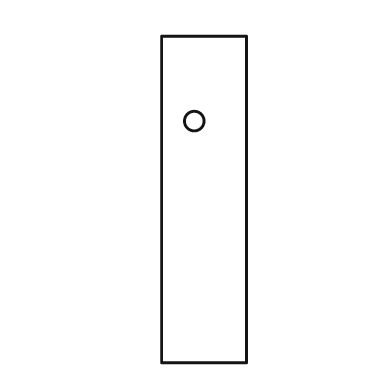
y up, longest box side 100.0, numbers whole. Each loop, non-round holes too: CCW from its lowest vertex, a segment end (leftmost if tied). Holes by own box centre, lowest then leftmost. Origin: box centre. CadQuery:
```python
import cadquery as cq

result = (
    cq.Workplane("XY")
    .moveTo(-13.0, -50.0)
    .lineTo(13.0, -50.0)
    .lineTo(13.0, 50.0)
    .lineTo(-13.0, 50.0)
    .close()
    .moveTo(-3.0, 24.0)
    .circle(3.0)
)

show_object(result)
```